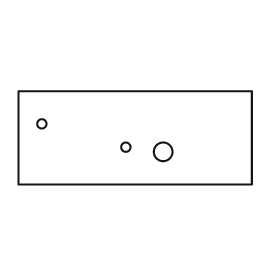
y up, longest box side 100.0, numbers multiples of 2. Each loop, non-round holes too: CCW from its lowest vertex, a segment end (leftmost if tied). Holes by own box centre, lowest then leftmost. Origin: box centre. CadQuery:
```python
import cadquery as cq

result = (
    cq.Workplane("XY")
    .moveTo(-50.0, -20.0)
    .lineTo(50.0, -20.0)
    .lineTo(50.0, 20.0)
    .lineTo(-50.0, 20.0)
    .close()
    .moveTo(12.0, -6.0)
    .circle(4.0)
    .moveTo(-4.0, -4.0)
    .circle(2.0)
    .moveTo(-40.0, 6.0)
    .circle(2.0)
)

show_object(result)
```